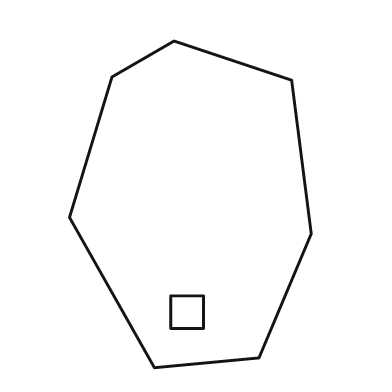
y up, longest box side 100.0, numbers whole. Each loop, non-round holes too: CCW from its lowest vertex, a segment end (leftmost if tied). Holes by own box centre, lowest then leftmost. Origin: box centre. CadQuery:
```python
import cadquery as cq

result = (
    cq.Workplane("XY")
    .moveTo(-11.0, -50.0)
    .lineTo(21.0, -47.0)
    .lineTo(37.0, -9.0)
    .lineTo(31.0, 38.0)
    .lineTo(-5.0, 50.0)
    .lineTo(-24.0, 39.0)
    .lineTo(-37.0, -4.0)
    .close()
    .moveTo(-6.0, -38.0)
    .lineTo(4.0, -38.0)
    .lineTo(4.0, -28.0)
    .lineTo(-6.0, -28.0)
    .close()
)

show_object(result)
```